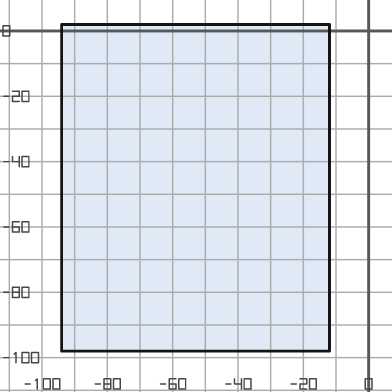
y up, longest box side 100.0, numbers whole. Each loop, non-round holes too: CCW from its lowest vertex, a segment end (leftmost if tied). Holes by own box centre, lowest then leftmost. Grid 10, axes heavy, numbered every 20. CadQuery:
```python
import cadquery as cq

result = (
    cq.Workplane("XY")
    .moveTo(-94.0, -98.0)
    .lineTo(-12.0, -98.0)
    .lineTo(-12.0, 2.0)
    .lineTo(-94.0, 2.0)
    .close()
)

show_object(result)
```